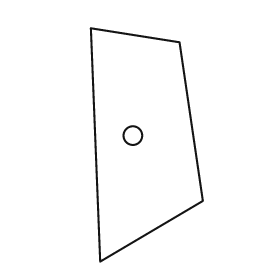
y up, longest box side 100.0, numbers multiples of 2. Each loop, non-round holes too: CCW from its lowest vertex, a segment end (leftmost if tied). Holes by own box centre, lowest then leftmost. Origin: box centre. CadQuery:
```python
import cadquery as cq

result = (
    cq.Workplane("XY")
    .moveTo(-20.0, -50.0)
    .lineTo(24.0, -24.0)
    .lineTo(14.0, 44.0)
    .lineTo(-24.0, 50.0)
    .close()
    .moveTo(-6.0, 4.0)
    .circle(4.0)
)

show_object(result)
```